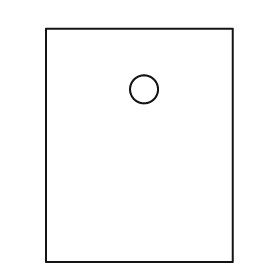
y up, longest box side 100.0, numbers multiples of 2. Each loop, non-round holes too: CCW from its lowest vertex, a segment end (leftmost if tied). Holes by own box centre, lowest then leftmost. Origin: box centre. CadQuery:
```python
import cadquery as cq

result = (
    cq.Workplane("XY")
    .moveTo(-40.0, -50.0)
    .lineTo(40.0, -50.0)
    .lineTo(40.0, 50.0)
    .lineTo(-40.0, 50.0)
    .close()
    .moveTo(2.0, 24.0)
    .circle(6.0)
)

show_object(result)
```